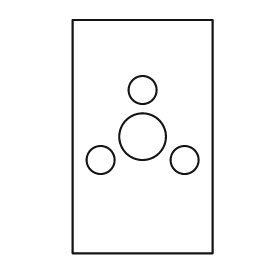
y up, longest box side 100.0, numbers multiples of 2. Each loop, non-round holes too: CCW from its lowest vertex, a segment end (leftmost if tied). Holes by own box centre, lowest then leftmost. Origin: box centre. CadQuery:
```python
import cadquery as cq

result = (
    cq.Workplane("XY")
    .moveTo(-30.0, -50.0)
    .lineTo(30.0, -50.0)
    .lineTo(30.0, 50.0)
    .lineTo(-30.0, 50.0)
    .close()
    .moveTo(-18.0, -10.0)
    .circle(6.0)
    .moveTo(18.0, -10.0)
    .circle(6.0)
    .moveTo(0.0, 0.0)
    .circle(10.0)
    .moveTo(0.0, 20.0)
    .circle(6.0)
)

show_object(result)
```